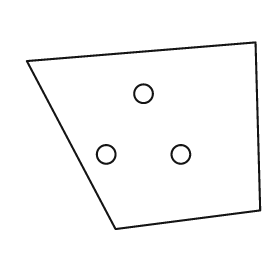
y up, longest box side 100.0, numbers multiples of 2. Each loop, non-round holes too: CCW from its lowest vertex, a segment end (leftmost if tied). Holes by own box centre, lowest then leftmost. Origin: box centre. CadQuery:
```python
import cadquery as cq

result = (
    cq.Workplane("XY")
    .moveTo(-12.0, -40.0)
    .lineTo(50.0, -32.0)
    .lineTo(48.0, 40.0)
    .lineTo(-50.0, 32.0)
    .close()
    .moveTo(-16.0, -8.0)
    .circle(4.0)
    .moveTo(16.0, -8.0)
    .circle(4.0)
    .moveTo(0.0, 18.0)
    .circle(4.0)
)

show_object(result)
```